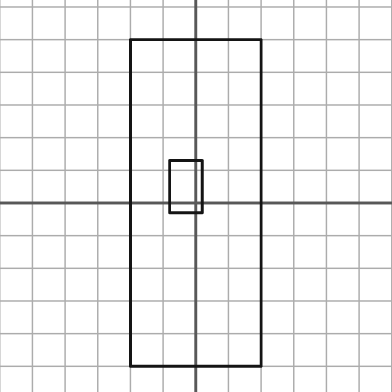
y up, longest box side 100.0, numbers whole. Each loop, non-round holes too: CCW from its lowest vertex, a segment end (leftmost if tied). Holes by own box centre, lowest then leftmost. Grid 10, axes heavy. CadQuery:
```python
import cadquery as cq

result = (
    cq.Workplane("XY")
    .moveTo(-20.0, -50.0)
    .lineTo(20.0, -50.0)
    .lineTo(20.0, 50.0)
    .lineTo(-20.0, 50.0)
    .close()
    .moveTo(-8.0, -3.0)
    .lineTo(2.0, -3.0)
    .lineTo(2.0, 13.0)
    .lineTo(-8.0, 13.0)
    .close()
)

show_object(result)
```